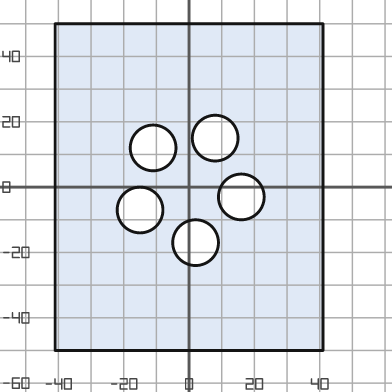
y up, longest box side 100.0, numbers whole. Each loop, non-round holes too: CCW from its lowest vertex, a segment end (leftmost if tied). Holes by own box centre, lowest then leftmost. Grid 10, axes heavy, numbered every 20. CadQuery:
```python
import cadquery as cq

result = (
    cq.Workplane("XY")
    .moveTo(-41.0, -50.0)
    .lineTo(41.0, -50.0)
    .lineTo(41.0, 50.0)
    .lineTo(-41.0, 50.0)
    .close()
    .moveTo(2.0, -17.0)
    .circle(7.0)
    .moveTo(-15.0, -7.0)
    .circle(7.0)
    .moveTo(16.0, -3.0)
    .circle(7.0)
    .moveTo(-11.0, 12.0)
    .circle(7.0)
    .moveTo(8.0, 15.0)
    .circle(7.0)
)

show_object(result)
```